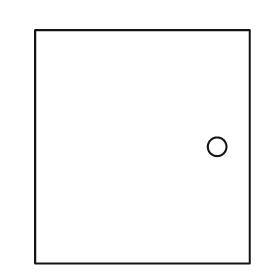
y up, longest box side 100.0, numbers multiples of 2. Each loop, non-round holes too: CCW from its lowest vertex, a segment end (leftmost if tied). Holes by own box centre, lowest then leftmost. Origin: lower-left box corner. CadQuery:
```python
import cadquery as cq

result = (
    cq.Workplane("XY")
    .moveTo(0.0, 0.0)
    .lineTo(92.0, 0.0)
    .lineTo(92.0, 100.0)
    .lineTo(0.0, 100.0)
    .close()
    .moveTo(78.0, 50.0)
    .circle(4.0)
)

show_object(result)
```